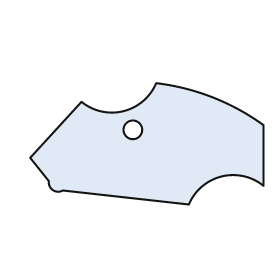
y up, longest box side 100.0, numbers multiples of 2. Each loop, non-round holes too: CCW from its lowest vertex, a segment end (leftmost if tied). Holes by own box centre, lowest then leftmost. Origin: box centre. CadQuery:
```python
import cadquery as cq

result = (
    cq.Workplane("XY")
    .moveTo(18.0, -26.0)
    .threePointArc((32.0, -14.0), (50.0, -18.0))
    .lineTo(50.0, 8.0)
    .threePointArc((28.0, 20.0), (4.0, 26.0))
    .threePointArc((-10.0, 14.0), (-28.0, 18.0))
    .lineTo(-50.0, -6.0)
    .lineTo(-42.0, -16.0)
    .threePointArc((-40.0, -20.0), (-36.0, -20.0))
    .close()
    .moveTo(-6.0, 6.0)
    .circle(4.0)
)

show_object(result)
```